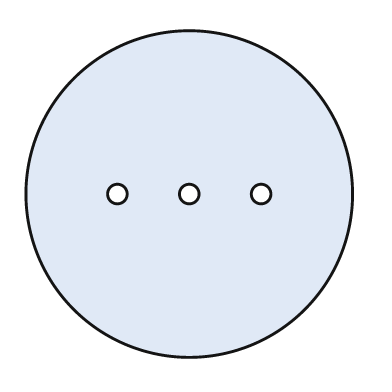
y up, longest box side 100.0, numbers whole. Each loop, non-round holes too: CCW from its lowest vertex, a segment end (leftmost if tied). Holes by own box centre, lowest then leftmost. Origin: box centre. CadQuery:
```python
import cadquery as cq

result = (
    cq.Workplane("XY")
    .moveTo(0.0, 0.0)
    .circle(50.0)
    .moveTo(-22.0, 0.0)
    .circle(3.0)
    .moveTo(0.0, 0.0)
    .circle(3.0)
    .moveTo(22.0, 0.0)
    .circle(3.0)
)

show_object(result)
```